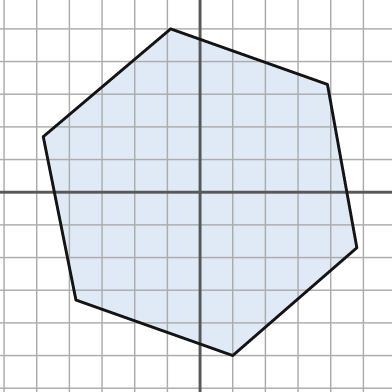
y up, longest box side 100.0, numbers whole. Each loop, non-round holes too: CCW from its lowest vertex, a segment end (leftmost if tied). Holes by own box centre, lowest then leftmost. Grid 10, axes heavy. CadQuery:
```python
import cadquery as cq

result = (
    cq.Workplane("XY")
    .moveTo(10.0, -50.0)
    .lineTo(48.0, -17.0)
    .lineTo(39.0, 33.0)
    .lineTo(-9.0, 50.0)
    .lineTo(-48.0, 17.0)
    .lineTo(-38.0, -33.0)
    .close()
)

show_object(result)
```